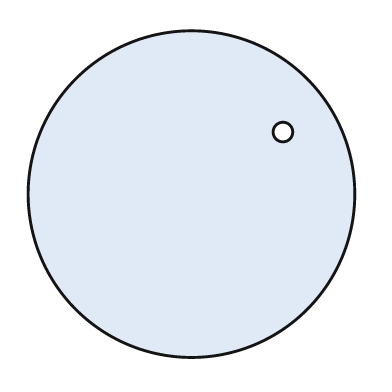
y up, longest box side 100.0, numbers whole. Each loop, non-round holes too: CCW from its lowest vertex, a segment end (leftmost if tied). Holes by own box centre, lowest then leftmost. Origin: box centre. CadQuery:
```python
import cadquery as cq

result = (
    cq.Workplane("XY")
    .moveTo(0.0, 0.0)
    .circle(50.0)
    .moveTo(28.0, 19.0)
    .circle(3.0)
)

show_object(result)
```